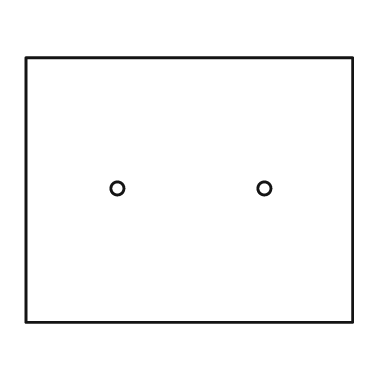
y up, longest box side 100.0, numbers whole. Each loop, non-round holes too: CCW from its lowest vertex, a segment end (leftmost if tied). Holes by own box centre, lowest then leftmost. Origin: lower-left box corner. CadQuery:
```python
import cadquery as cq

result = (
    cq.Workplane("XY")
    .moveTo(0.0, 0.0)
    .lineTo(100.0, 0.0)
    .lineTo(100.0, 81.0)
    .lineTo(0.0, 81.0)
    .close()
    .moveTo(28.0, 41.0)
    .circle(2.0)
    .moveTo(73.0, 41.0)
    .circle(2.0)
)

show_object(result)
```